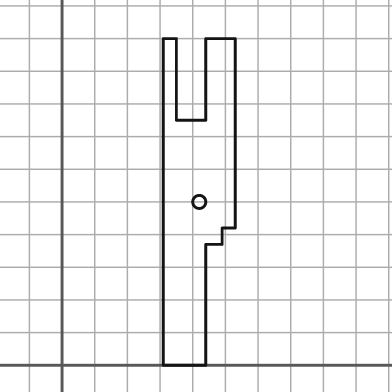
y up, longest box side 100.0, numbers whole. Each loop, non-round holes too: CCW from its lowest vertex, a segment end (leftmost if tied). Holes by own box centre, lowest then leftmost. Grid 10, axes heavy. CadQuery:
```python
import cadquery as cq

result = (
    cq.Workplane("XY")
    .moveTo(31.0, 0.0)
    .lineTo(44.0, 0.0)
    .lineTo(44.0, 37.0)
    .lineTo(49.0, 37.0)
    .lineTo(49.0, 42.0)
    .lineTo(53.0, 42.0)
    .lineTo(53.0, 100.0)
    .lineTo(44.0, 100.0)
    .lineTo(44.0, 75.0)
    .lineTo(35.0, 75.0)
    .lineTo(35.0, 100.0)
    .lineTo(31.0, 100.0)
    .close()
    .moveTo(42.0, 50.0)
    .circle(2.0)
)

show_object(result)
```